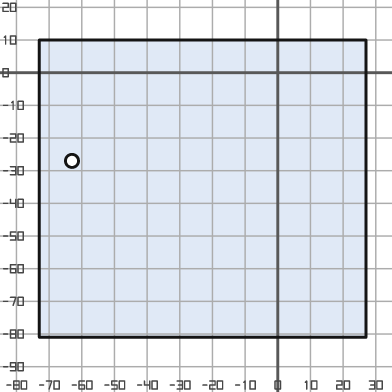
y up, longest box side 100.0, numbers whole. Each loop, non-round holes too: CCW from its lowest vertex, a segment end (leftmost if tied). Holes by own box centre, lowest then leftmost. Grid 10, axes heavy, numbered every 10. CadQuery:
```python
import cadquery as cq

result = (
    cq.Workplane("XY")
    .moveTo(-73.0, -81.0)
    .lineTo(27.0, -81.0)
    .lineTo(27.0, 10.0)
    .lineTo(-73.0, 10.0)
    .close()
    .moveTo(-63.0, -27.0)
    .circle(2.0)
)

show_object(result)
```